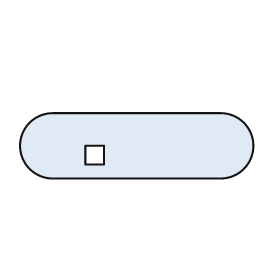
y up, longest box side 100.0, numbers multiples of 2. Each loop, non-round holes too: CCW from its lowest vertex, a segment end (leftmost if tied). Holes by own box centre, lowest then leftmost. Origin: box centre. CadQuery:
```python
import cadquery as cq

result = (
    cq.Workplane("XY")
    .moveTo(-36.0, -14.0)
    .lineTo(36.0, -14.0)
    .threePointArc((50.0, 0.0), (36.0, 14.0))
    .lineTo(-36.0, 14.0)
    .threePointArc((-50.0, 0.0), (-36.0, -14.0))
    .close()
    .moveTo(-22.0, -8.0)
    .lineTo(-14.0, -8.0)
    .lineTo(-14.0, 0.0)
    .lineTo(-22.0, 0.0)
    .close()
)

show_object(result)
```